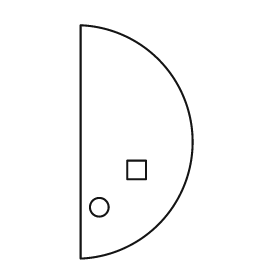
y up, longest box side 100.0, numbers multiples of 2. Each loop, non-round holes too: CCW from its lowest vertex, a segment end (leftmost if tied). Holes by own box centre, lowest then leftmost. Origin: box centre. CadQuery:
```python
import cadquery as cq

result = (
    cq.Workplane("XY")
    .moveTo(-24.0, -50.0)
    .threePointArc((24.0, 0.0), (-24.0, 50.0))
    .close()
    .moveTo(-16.0, -28.0)
    .circle(4.0)
    .moveTo(-4.0, -16.0)
    .lineTo(4.0, -16.0)
    .lineTo(4.0, -8.0)
    .lineTo(-4.0, -8.0)
    .close()
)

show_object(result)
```